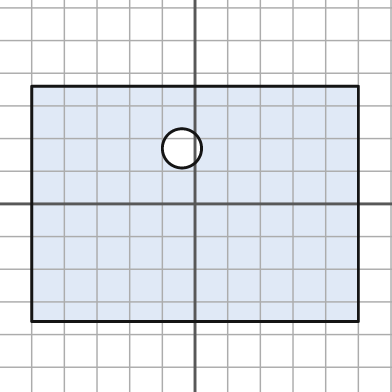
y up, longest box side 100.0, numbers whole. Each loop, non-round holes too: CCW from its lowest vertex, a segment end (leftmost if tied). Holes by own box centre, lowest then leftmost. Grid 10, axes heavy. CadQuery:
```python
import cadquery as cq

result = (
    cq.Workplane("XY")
    .moveTo(-50.0, -36.0)
    .lineTo(50.0, -36.0)
    .lineTo(50.0, 36.0)
    .lineTo(-50.0, 36.0)
    .close()
    .moveTo(-4.0, 17.0)
    .circle(6.0)
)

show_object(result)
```